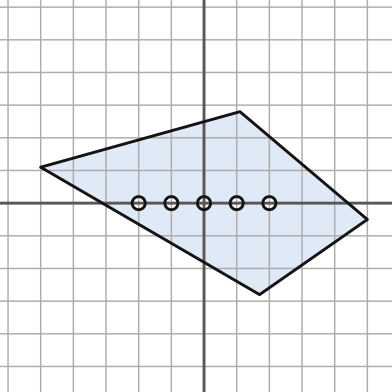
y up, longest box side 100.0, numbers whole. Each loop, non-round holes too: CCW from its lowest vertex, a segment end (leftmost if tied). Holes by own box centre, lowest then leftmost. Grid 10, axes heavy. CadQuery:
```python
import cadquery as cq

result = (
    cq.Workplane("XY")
    .moveTo(17.0, -28.0)
    .lineTo(50.0, -5.0)
    .lineTo(11.0, 28.0)
    .lineTo(-50.0, 11.0)
    .close()
    .moveTo(-20.0, 0.0)
    .circle(2.0)
    .moveTo(-10.0, 0.0)
    .circle(2.0)
    .moveTo(0.0, 0.0)
    .circle(2.0)
    .moveTo(10.0, 0.0)
    .circle(2.0)
    .moveTo(20.0, 0.0)
    .circle(2.0)
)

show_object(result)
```